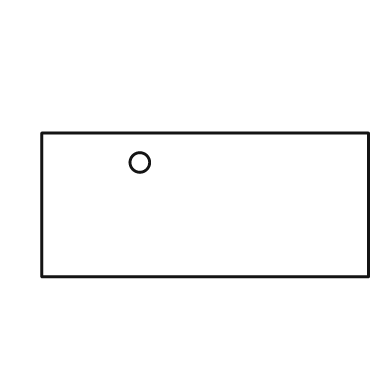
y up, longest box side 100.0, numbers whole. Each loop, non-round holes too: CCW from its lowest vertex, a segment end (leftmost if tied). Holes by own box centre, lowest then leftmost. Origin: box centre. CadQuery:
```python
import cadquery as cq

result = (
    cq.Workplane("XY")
    .moveTo(-50.0, -22.0)
    .lineTo(50.0, -22.0)
    .lineTo(50.0, 22.0)
    .lineTo(-50.0, 22.0)
    .close()
    .moveTo(-20.0, 13.0)
    .circle(3.0)
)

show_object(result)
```